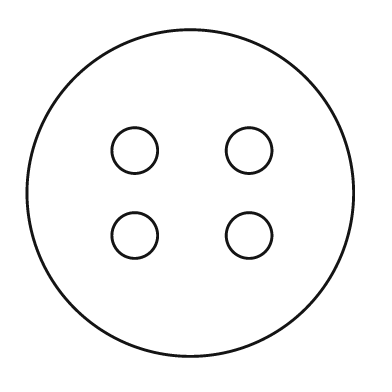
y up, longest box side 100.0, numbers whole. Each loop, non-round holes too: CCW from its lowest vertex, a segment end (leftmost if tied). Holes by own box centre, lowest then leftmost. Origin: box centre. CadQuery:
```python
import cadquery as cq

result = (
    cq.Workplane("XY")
    .moveTo(0.0, 0.0)
    .circle(50.0)
    .moveTo(-17.0, -13.0)
    .circle(7.0)
    .moveTo(18.0, -13.0)
    .circle(7.0)
    .moveTo(-17.0, 13.0)
    .circle(7.0)
    .moveTo(18.0, 13.0)
    .circle(7.0)
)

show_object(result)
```